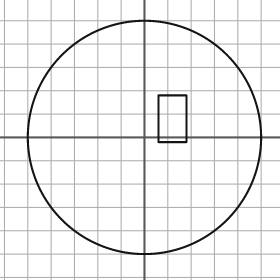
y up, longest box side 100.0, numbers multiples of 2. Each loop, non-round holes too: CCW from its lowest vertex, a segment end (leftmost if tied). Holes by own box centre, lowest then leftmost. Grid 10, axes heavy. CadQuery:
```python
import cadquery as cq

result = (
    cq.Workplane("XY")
    .moveTo(0.0, 0.0)
    .circle(50.0)
    .moveTo(6.0, -2.0)
    .lineTo(18.0, -2.0)
    .lineTo(18.0, 18.0)
    .lineTo(6.0, 18.0)
    .close()
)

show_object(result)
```